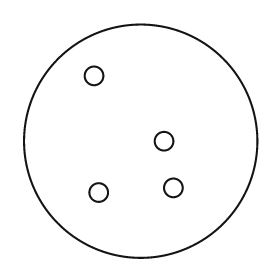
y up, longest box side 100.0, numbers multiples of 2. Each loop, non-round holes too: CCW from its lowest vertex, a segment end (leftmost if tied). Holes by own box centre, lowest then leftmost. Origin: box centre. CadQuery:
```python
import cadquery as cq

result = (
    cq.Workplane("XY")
    .moveTo(0.0, 0.0)
    .circle(50.0)
    .moveTo(-18.0, -22.0)
    .circle(4.0)
    .moveTo(14.0, -20.0)
    .circle(4.0)
    .moveTo(10.0, 0.0)
    .circle(4.0)
    .moveTo(-20.0, 28.0)
    .circle(4.0)
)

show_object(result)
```